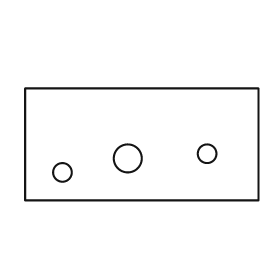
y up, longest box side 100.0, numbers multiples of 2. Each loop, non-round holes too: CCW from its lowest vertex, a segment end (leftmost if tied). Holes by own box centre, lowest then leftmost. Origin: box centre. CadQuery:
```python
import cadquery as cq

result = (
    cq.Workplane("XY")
    .moveTo(-50.0, -24.0)
    .lineTo(50.0, -24.0)
    .lineTo(50.0, 24.0)
    .lineTo(-50.0, 24.0)
    .close()
    .moveTo(-34.0, -12.0)
    .circle(4.0)
    .moveTo(-6.0, -6.0)
    .circle(6.0)
    .moveTo(28.0, -4.0)
    .circle(4.0)
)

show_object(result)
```